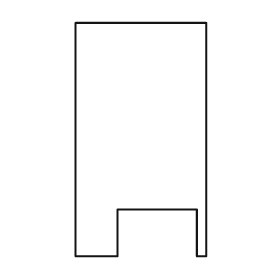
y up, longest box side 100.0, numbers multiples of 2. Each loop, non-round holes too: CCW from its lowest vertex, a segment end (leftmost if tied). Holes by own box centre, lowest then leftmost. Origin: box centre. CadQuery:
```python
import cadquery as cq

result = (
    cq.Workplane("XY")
    .moveTo(-28.0, -50.0)
    .lineTo(-10.0, -50.0)
    .lineTo(-10.0, -30.0)
    .lineTo(24.0, -30.0)
    .lineTo(24.0, -50.0)
    .lineTo(28.0, -50.0)
    .lineTo(28.0, 50.0)
    .lineTo(-28.0, 50.0)
    .close()
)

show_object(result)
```